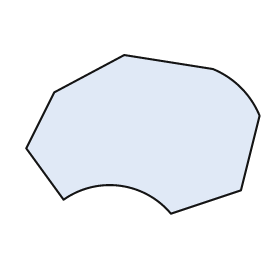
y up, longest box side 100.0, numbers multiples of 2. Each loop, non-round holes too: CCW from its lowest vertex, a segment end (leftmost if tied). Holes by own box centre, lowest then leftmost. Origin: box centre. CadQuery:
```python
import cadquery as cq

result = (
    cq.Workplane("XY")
    .moveTo(12.0, -34.0)
    .lineTo(42.0, -24.0)
    .lineTo(50.0, 8.0)
    .threePointArc((42.0, 20.0), (30.0, 28.0))
    .lineTo(-8.0, 34.0)
    .lineTo(-38.0, 18.0)
    .lineTo(-50.0, -6.0)
    .lineTo(-34.0, -28.0)
    .threePointArc((-10.0, -22.0), (12.0, -34.0))
    .close()
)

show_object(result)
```